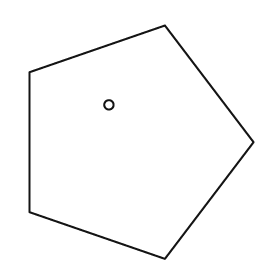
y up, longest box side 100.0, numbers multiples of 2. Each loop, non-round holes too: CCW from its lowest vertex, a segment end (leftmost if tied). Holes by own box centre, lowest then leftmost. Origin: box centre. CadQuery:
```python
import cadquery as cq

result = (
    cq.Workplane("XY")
    .moveTo(10.0, -50.0)
    .lineTo(48.0, 0.0)
    .lineTo(10.0, 50.0)
    .lineTo(-48.0, 30.0)
    .lineTo(-48.0, -30.0)
    .close()
    .moveTo(-14.0, 16.0)
    .circle(2.0)
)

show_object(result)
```